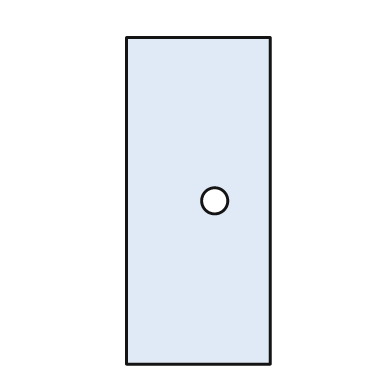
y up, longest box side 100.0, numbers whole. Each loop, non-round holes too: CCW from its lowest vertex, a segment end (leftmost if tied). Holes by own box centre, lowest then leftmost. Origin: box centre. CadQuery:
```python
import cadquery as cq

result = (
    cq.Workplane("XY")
    .moveTo(-22.0, -50.0)
    .lineTo(22.0, -50.0)
    .lineTo(22.0, 50.0)
    .lineTo(-22.0, 50.0)
    .close()
    .moveTo(5.0, 0.0)
    .circle(4.0)
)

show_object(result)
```